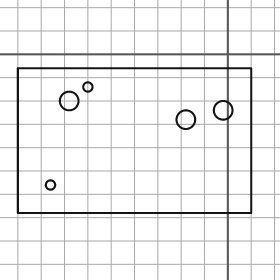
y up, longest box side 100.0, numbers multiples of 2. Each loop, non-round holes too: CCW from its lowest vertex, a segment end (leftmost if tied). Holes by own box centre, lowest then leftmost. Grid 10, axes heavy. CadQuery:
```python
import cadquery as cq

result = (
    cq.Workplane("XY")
    .moveTo(-90.0, -68.0)
    .lineTo(10.0, -68.0)
    .lineTo(10.0, -6.0)
    .lineTo(-90.0, -6.0)
    .close()
    .moveTo(-76.0, -56.0)
    .circle(2.0)
    .moveTo(-18.0, -28.0)
    .circle(4.0)
    .moveTo(-2.0, -24.0)
    .circle(4.0)
    .moveTo(-68.0, -20.0)
    .circle(4.0)
    .moveTo(-60.0, -14.0)
    .circle(2.0)
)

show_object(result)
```